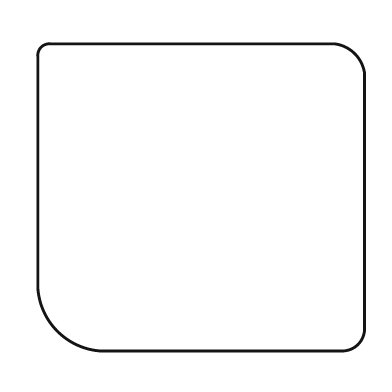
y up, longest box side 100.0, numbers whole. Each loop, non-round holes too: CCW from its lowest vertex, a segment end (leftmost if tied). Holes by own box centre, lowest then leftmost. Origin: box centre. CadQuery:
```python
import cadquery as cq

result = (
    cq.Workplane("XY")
    .moveTo(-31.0, -47.0)
    .lineTo(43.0, -47.0)
    .threePointArc((48.0, -45.0), (50.0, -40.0))
    .lineTo(50.0, 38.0)
    .threePointArc((47.0, 44.0), (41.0, 47.0))
    .lineTo(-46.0, 47.0)
    .threePointArc((-49.0, 46.0), (-50.0, 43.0))
    .lineTo(-50.0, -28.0)
    .threePointArc((-44.0, -41.0), (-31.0, -47.0))
    .close()
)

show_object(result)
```